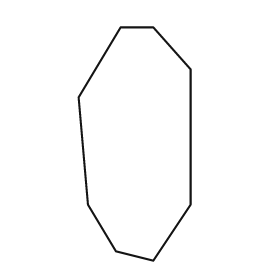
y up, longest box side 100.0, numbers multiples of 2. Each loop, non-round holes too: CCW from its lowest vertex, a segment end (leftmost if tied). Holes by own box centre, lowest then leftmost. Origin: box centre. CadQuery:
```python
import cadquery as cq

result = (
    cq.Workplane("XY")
    .moveTo(8.0, -50.0)
    .lineTo(24.0, -26.0)
    .lineTo(24.0, 32.0)
    .lineTo(8.0, 50.0)
    .lineTo(-6.0, 50.0)
    .lineTo(-24.0, 20.0)
    .lineTo(-20.0, -26.0)
    .lineTo(-8.0, -46.0)
    .close()
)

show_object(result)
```